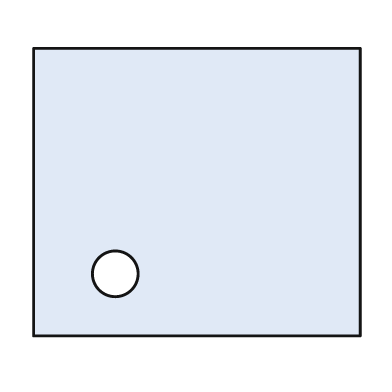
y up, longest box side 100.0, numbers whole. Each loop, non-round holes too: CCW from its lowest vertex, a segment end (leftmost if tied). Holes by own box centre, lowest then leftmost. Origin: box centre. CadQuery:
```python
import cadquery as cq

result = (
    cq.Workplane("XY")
    .moveTo(-50.0, -44.0)
    .lineTo(50.0, -44.0)
    .lineTo(50.0, 44.0)
    .lineTo(-50.0, 44.0)
    .close()
    .moveTo(-25.0, -25.0)
    .circle(7.0)
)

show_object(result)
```